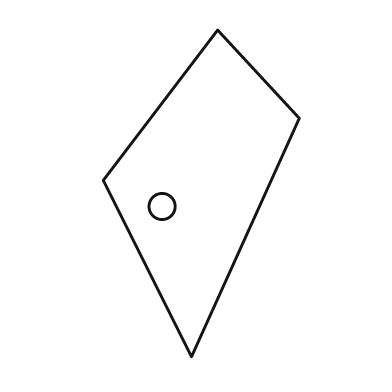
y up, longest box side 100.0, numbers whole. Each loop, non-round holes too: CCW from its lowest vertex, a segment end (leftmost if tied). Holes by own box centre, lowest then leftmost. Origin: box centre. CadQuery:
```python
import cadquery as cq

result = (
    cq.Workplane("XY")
    .moveTo(-3.0, -50.0)
    .lineTo(30.0, 23.0)
    .lineTo(5.0, 50.0)
    .lineTo(-30.0, 4.0)
    .close()
    .moveTo(-12.0, -4.0)
    .circle(4.0)
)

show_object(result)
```